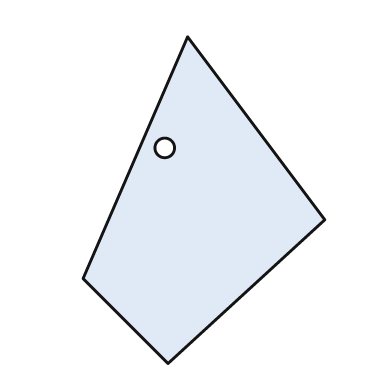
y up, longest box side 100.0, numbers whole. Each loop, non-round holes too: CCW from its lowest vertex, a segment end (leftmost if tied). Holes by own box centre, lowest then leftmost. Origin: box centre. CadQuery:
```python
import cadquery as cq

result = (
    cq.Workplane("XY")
    .moveTo(-11.0, -50.0)
    .lineTo(37.0, -6.0)
    .lineTo(-5.0, 50.0)
    .lineTo(-37.0, -24.0)
    .close()
    .moveTo(-12.0, 16.0)
    .circle(3.0)
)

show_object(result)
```